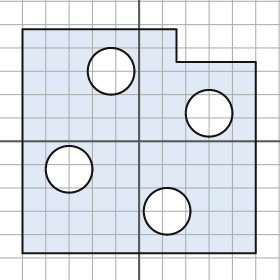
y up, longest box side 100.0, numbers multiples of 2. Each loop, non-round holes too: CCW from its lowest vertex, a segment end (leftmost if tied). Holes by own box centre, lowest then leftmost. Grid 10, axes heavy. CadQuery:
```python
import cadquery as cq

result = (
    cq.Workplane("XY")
    .moveTo(-50.0, -48.0)
    .lineTo(50.0, -48.0)
    .lineTo(50.0, 34.0)
    .lineTo(16.0, 34.0)
    .lineTo(16.0, 48.0)
    .lineTo(-50.0, 48.0)
    .close()
    .moveTo(12.0, -30.0)
    .circle(10.0)
    .moveTo(-30.0, -12.0)
    .circle(10.0)
    .moveTo(30.0, 12.0)
    .circle(10.0)
    .moveTo(-12.0, 30.0)
    .circle(10.0)
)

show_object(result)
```